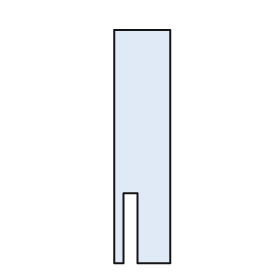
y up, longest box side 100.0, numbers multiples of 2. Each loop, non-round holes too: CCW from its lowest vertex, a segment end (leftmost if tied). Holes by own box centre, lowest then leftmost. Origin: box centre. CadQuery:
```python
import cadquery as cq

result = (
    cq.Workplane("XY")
    .moveTo(-12.0, -50.0)
    .lineTo(-8.0, -50.0)
    .lineTo(-8.0, -20.0)
    .lineTo(-2.0, -20.0)
    .lineTo(-2.0, -50.0)
    .lineTo(12.0, -50.0)
    .lineTo(12.0, 50.0)
    .lineTo(-12.0, 50.0)
    .close()
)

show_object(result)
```